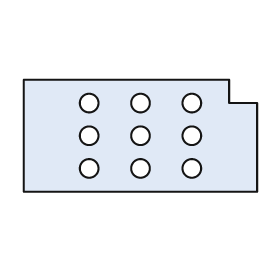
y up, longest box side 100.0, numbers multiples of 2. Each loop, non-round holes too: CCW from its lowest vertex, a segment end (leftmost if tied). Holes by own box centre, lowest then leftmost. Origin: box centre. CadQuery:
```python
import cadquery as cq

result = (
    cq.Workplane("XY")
    .moveTo(-50.0, -24.0)
    .lineTo(50.0, -24.0)
    .lineTo(50.0, 14.0)
    .lineTo(38.0, 14.0)
    .lineTo(38.0, 24.0)
    .lineTo(-50.0, 24.0)
    .close()
    .moveTo(-22.0, -14.0)
    .circle(4.0)
    .moveTo(0.0, -14.0)
    .circle(4.0)
    .moveTo(22.0, -14.0)
    .circle(4.0)
    .moveTo(-22.0, 0.0)
    .circle(4.0)
    .moveTo(0.0, 0.0)
    .circle(4.0)
    .moveTo(22.0, 0.0)
    .circle(4.0)
    .moveTo(-22.0, 14.0)
    .circle(4.0)
    .moveTo(0.0, 14.0)
    .circle(4.0)
    .moveTo(22.0, 14.0)
    .circle(4.0)
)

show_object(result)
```